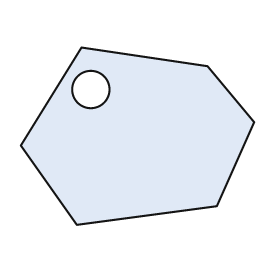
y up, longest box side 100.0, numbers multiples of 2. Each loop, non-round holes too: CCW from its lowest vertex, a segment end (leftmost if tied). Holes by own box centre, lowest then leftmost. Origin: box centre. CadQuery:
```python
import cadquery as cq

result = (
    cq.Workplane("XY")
    .moveTo(-26.0, -38.0)
    .lineTo(34.0, -30.0)
    .lineTo(50.0, 6.0)
    .lineTo(30.0, 30.0)
    .lineTo(-24.0, 38.0)
    .lineTo(-50.0, -4.0)
    .close()
    .moveTo(-20.0, 20.0)
    .circle(8.0)
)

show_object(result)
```